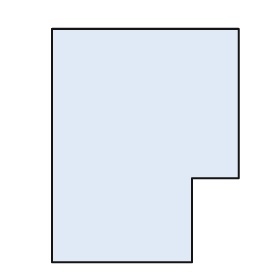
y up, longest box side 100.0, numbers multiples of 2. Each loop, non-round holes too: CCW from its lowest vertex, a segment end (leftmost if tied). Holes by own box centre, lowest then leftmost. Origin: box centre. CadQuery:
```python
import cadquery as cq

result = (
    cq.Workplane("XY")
    .moveTo(-40.0, -50.0)
    .lineTo(20.0, -50.0)
    .lineTo(20.0, -14.0)
    .lineTo(40.0, -14.0)
    .lineTo(40.0, 50.0)
    .lineTo(-40.0, 50.0)
    .close()
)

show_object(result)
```